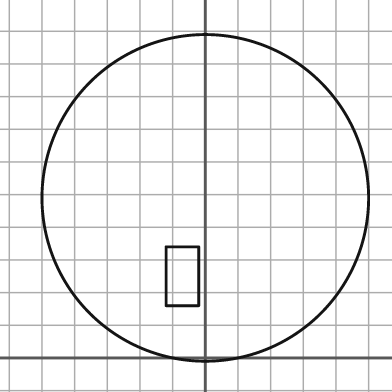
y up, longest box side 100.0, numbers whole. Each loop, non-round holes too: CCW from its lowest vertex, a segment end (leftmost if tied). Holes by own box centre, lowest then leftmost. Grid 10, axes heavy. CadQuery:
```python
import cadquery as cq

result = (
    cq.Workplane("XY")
    .moveTo(0.0, 49.0)
    .circle(50.0)
    .moveTo(-12.0, 16.0)
    .lineTo(-2.0, 16.0)
    .lineTo(-2.0, 34.0)
    .lineTo(-12.0, 34.0)
    .close()
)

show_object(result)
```